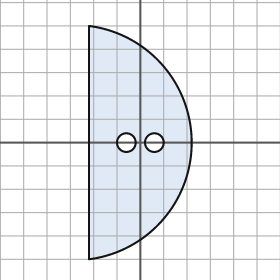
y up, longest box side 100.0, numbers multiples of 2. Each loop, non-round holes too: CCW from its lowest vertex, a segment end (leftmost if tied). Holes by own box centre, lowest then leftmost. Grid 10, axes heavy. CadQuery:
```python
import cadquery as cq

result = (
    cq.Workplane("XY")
    .moveTo(-22.0, -50.0)
    .threePointArc((22.0, 0.0), (-22.0, 50.0))
    .close()
    .moveTo(-6.0, 0.0)
    .circle(4.0)
    .moveTo(6.0, 0.0)
    .circle(4.0)
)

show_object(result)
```